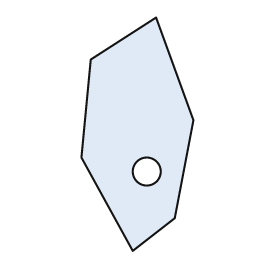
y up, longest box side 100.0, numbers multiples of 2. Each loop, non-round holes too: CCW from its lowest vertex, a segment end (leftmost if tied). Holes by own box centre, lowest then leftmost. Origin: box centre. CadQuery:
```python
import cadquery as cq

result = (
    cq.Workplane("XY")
    .moveTo(-2.0, -50.0)
    .lineTo(16.0, -36.0)
    .lineTo(24.0, 6.0)
    .lineTo(8.0, 50.0)
    .lineTo(-20.0, 32.0)
    .lineTo(-24.0, -10.0)
    .close()
    .moveTo(4.0, -16.0)
    .circle(6.0)
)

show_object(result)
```